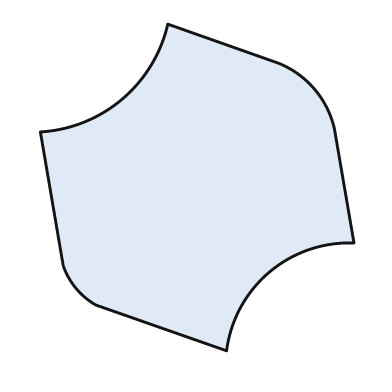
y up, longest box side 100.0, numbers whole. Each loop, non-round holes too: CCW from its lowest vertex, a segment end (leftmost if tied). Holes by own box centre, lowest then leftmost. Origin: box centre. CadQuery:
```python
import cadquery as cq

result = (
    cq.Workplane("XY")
    .moveTo(9.0, -50.0)
    .threePointArc((22.0, -26.0), (48.0, -17.0))
    .lineTo(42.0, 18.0)
    .threePointArc((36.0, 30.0), (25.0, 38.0))
    .lineTo(-9.0, 50.0)
    .threePointArc((-23.0, 27.0), (-48.0, 17.0))
    .lineTo(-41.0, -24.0)
    .threePointArc((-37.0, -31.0), (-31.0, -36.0))
    .close()
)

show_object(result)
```